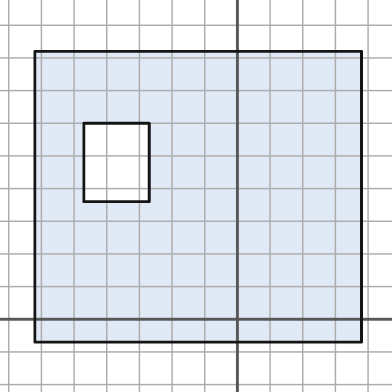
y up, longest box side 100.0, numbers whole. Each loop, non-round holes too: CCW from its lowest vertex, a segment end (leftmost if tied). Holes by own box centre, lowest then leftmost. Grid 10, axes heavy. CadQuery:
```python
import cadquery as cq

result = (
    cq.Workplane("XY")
    .moveTo(-62.0, -7.0)
    .lineTo(38.0, -7.0)
    .lineTo(38.0, 82.0)
    .lineTo(-62.0, 82.0)
    .close()
    .moveTo(-47.0, 36.0)
    .lineTo(-27.0, 36.0)
    .lineTo(-27.0, 60.0)
    .lineTo(-47.0, 60.0)
    .close()
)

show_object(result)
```